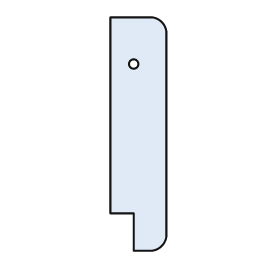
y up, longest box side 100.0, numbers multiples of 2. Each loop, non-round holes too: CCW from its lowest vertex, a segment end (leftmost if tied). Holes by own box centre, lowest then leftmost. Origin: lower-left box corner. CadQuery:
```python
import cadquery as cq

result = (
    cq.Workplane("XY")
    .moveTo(10.0, 0.0)
    .lineTo(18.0, 0.0)
    .threePointArc((22.0, 2.0), (24.0, 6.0))
    .lineTo(24.0, 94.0)
    .threePointArc((22.0, 98.0), (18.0, 100.0))
    .lineTo(0.0, 100.0)
    .lineTo(0.0, 16.0)
    .lineTo(10.0, 16.0)
    .close()
    .moveTo(10.0, 80.0)
    .circle(2.0)
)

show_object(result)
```